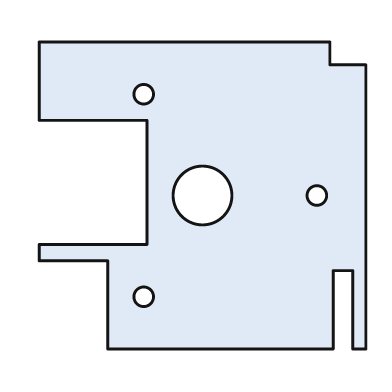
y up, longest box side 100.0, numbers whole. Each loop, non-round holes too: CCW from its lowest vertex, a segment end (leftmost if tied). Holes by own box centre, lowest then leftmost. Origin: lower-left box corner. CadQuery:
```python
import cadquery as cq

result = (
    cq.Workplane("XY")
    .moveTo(21.0, 0.0)
    .lineTo(90.0, 0.0)
    .lineTo(90.0, 24.0)
    .lineTo(96.0, 24.0)
    .lineTo(96.0, 0.0)
    .lineTo(100.0, 0.0)
    .lineTo(100.0, 87.0)
    .lineTo(89.0, 87.0)
    .lineTo(89.0, 94.0)
    .lineTo(0.0, 94.0)
    .lineTo(0.0, 70.0)
    .lineTo(33.0, 70.0)
    .lineTo(33.0, 32.0)
    .lineTo(0.0, 32.0)
    .lineTo(0.0, 27.0)
    .lineTo(21.0, 27.0)
    .close()
    .moveTo(32.0, 16.0)
    .circle(3.0)
    .moveTo(50.0, 47.0)
    .circle(9.0)
    .moveTo(85.0, 47.0)
    .circle(3.0)
    .moveTo(32.0, 78.0)
    .circle(3.0)
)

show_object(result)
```